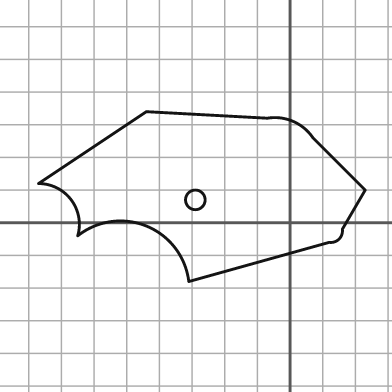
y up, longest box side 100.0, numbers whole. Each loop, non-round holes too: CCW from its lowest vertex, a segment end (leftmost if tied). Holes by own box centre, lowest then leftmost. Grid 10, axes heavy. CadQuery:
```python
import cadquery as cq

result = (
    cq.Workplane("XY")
    .moveTo(-31.0, -18.0)
    .lineTo(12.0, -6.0)
    .threePointArc((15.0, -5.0), (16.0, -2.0))
    .lineTo(23.0, 10.0)
    .lineTo(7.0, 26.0)
    .threePointArc((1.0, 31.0), (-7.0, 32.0))
    .lineTo(-44.0, 34.0)
    .lineTo(-77.0, 12.0)
    .threePointArc((-67.0, 7.0), (-65.0, -4.0))
    .threePointArc((-44.0, -1.0), (-31.0, -18.0))
    .close()
    .moveTo(-29.0, 7.0)
    .circle(3.0)
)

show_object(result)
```